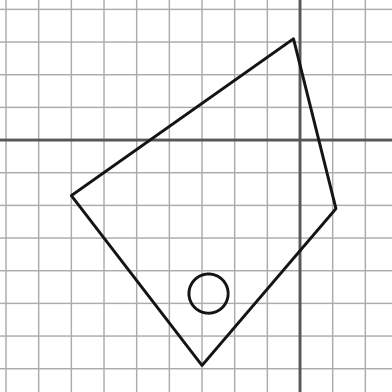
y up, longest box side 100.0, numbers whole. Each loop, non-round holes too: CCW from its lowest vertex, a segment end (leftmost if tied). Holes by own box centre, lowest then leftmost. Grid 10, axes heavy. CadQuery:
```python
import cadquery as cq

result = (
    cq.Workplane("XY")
    .moveTo(-30.0, -69.0)
    .lineTo(11.0, -21.0)
    .lineTo(-2.0, 31.0)
    .lineTo(-70.0, -17.0)
    .close()
    .moveTo(-28.0, -47.0)
    .circle(6.0)
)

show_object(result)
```